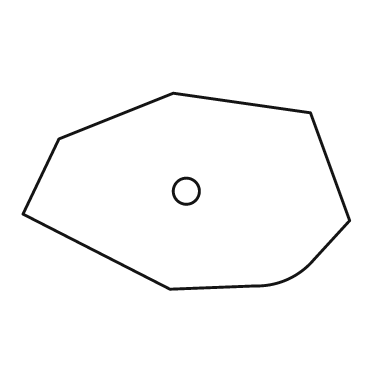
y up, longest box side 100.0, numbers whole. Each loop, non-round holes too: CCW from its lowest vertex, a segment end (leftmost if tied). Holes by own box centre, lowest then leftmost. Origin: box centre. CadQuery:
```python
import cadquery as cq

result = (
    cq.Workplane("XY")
    .moveTo(-5.0, -30.0)
    .lineTo(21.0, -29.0)
    .threePointArc((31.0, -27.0), (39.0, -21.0))
    .lineTo(50.0, -9.0)
    .lineTo(38.0, 24.0)
    .lineTo(-4.0, 30.0)
    .lineTo(-39.0, 16.0)
    .lineTo(-50.0, -7.0)
    .close()
    .moveTo(0.0, 0.0)
    .circle(4.0)
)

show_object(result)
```